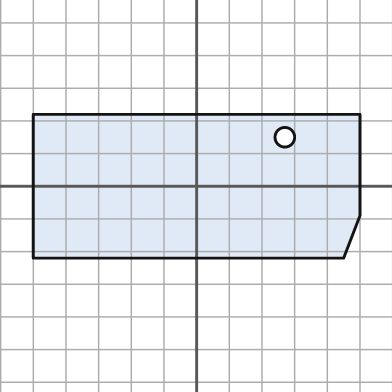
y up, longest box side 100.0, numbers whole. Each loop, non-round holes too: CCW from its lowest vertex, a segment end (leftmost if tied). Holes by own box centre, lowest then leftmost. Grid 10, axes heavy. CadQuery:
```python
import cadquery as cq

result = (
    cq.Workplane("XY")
    .moveTo(-50.0, -22.0)
    .lineTo(45.0, -22.0)
    .lineTo(50.0, -9.0)
    .lineTo(50.0, 22.0)
    .lineTo(-50.0, 22.0)
    .close()
    .moveTo(27.0, 15.0)
    .circle(3.0)
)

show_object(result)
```